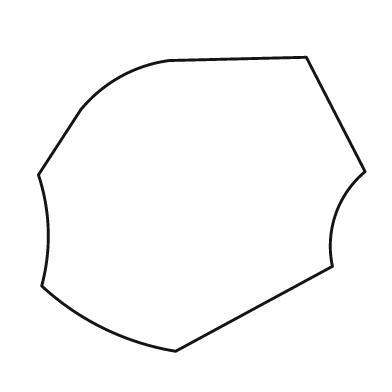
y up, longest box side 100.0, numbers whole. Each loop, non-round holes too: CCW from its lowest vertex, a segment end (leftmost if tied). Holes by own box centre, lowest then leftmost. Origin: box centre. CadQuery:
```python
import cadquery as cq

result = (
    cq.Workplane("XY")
    .moveTo(-8.0, -45.0)
    .lineTo(40.0, -19.0)
    .threePointArc((41.0, -3.0), (50.0, 10.0))
    .lineTo(32.0, 45.0)
    .lineTo(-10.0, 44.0)
    .threePointArc((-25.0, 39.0), (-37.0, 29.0))
    .lineTo(-50.0, 9.0)
    .threePointArc((-47.0, -8.0), (-49.0, -25.0))
    .threePointArc((-30.0, -38.0), (-8.0, -45.0))
    .close()
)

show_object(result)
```